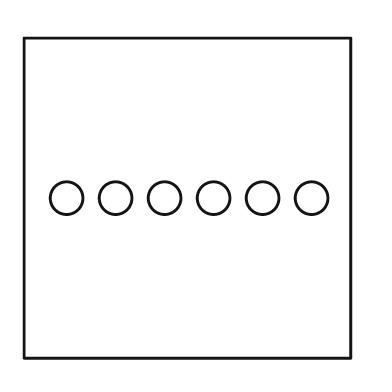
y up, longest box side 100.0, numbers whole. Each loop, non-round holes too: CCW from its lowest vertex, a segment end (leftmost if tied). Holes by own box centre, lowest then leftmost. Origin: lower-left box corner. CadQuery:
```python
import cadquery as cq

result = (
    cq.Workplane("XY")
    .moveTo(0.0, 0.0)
    .lineTo(100.0, 0.0)
    .lineTo(100.0, 98.0)
    .lineTo(0.0, 98.0)
    .close()
    .moveTo(13.0, 49.0)
    .circle(5.0)
    .moveTo(28.0, 49.0)
    .circle(5.0)
    .moveTo(43.0, 49.0)
    .circle(5.0)
    .moveTo(58.0, 49.0)
    .circle(5.0)
    .moveTo(73.0, 49.0)
    .circle(5.0)
    .moveTo(88.0, 49.0)
    .circle(5.0)
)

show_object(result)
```